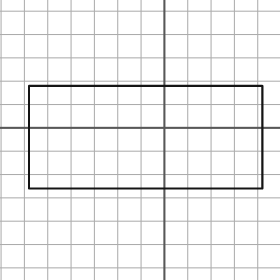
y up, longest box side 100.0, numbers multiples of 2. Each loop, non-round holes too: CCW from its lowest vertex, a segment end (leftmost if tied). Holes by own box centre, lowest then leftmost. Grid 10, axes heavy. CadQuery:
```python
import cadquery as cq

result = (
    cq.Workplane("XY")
    .moveTo(-58.0, -26.0)
    .lineTo(42.0, -26.0)
    .lineTo(42.0, 18.0)
    .lineTo(-58.0, 18.0)
    .close()
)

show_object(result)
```